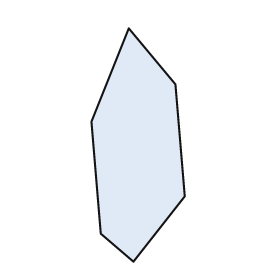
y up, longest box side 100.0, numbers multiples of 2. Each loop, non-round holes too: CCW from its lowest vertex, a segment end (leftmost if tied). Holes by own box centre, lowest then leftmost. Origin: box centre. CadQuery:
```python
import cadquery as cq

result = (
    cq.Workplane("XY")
    .moveTo(-2.0, -50.0)
    .lineTo(20.0, -22.0)
    .lineTo(16.0, 26.0)
    .lineTo(-4.0, 50.0)
    .lineTo(-20.0, 10.0)
    .lineTo(-16.0, -38.0)
    .close()
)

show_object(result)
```